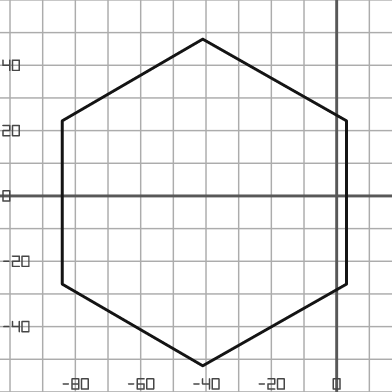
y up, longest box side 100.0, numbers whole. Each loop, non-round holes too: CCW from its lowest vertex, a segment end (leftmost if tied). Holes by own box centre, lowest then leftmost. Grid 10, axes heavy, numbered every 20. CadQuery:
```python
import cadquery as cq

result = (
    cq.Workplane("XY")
    .moveTo(-41.0, -52.0)
    .lineTo(3.0, -27.0)
    .lineTo(3.0, 23.0)
    .lineTo(-41.0, 48.0)
    .lineTo(-84.0, 23.0)
    .lineTo(-84.0, -27.0)
    .close()
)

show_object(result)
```